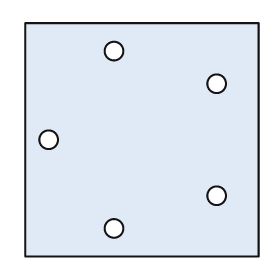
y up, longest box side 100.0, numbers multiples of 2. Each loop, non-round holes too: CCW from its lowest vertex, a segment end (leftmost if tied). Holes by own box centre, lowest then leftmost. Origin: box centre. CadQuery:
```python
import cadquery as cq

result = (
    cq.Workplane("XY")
    .moveTo(-50.0, -50.0)
    .lineTo(50.0, -50.0)
    .lineTo(50.0, 50.0)
    .lineTo(-50.0, 50.0)
    .close()
    .moveTo(-12.0, -38.0)
    .circle(4.0)
    .moveTo(32.0, -24.0)
    .circle(4.0)
    .moveTo(-40.0, 0.0)
    .circle(4.0)
    .moveTo(32.0, 24.0)
    .circle(4.0)
    .moveTo(-12.0, 38.0)
    .circle(4.0)
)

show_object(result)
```